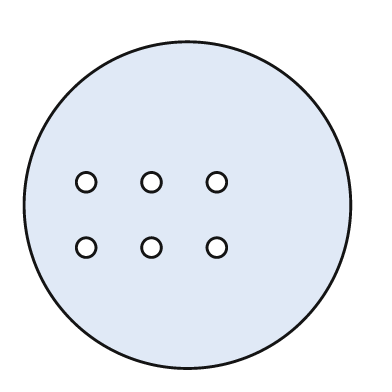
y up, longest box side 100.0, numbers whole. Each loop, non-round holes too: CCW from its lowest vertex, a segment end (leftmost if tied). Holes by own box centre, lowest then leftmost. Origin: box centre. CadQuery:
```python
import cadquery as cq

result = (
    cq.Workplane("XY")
    .moveTo(0.0, 0.0)
    .circle(50.0)
    .moveTo(-31.0, -13.0)
    .circle(3.0)
    .moveTo(-11.0, -13.0)
    .circle(3.0)
    .moveTo(9.0, -13.0)
    .circle(3.0)
    .moveTo(-31.0, 7.0)
    .circle(3.0)
    .moveTo(-11.0, 7.0)
    .circle(3.0)
    .moveTo(9.0, 7.0)
    .circle(3.0)
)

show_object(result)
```